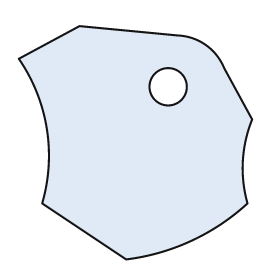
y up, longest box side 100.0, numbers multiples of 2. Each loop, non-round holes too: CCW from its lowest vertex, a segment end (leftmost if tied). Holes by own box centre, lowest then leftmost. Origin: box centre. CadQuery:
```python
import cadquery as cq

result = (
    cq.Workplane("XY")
    .moveTo(-4.0, -50.0)
    .threePointArc((24.0, -42.0), (48.0, -26.0))
    .threePointArc((46.0, -8.0), (50.0, 10.0))
    .lineTo(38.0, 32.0)
    .threePointArc((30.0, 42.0), (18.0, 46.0))
    .lineTo(-24.0, 50.0)
    .lineTo(-50.0, 36.0)
    .threePointArc((-38.0, 6.0), (-40.0, -26.0))
    .close()
    .moveTo(14.0, 24.0)
    .circle(8.0)
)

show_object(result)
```